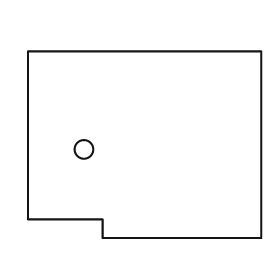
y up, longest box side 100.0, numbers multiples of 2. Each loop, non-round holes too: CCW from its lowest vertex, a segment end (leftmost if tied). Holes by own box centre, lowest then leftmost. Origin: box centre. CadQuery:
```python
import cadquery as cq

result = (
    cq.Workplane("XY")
    .moveTo(-18.0, -40.0)
    .lineTo(50.0, -40.0)
    .lineTo(50.0, 40.0)
    .lineTo(-50.0, 40.0)
    .lineTo(-50.0, -32.0)
    .lineTo(-18.0, -32.0)
    .close()
    .moveTo(-26.0, -2.0)
    .circle(4.0)
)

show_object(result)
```